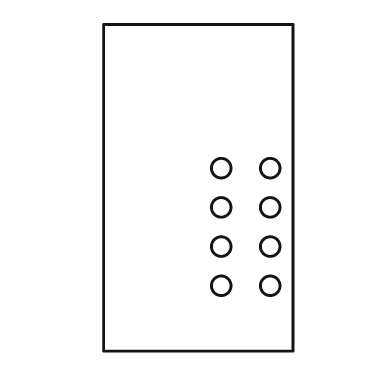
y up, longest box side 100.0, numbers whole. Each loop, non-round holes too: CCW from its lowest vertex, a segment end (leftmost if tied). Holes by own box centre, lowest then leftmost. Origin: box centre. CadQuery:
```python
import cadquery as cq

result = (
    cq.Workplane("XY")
    .moveTo(-29.0, -50.0)
    .lineTo(29.0, -50.0)
    .lineTo(29.0, 50.0)
    .lineTo(-29.0, 50.0)
    .close()
    .moveTo(7.0, -30.0)
    .circle(3.0)
    .moveTo(22.0, -30.0)
    .circle(3.0)
    .moveTo(7.0, -18.0)
    .circle(3.0)
    .moveTo(22.0, -18.0)
    .circle(3.0)
    .moveTo(7.0, -6.0)
    .circle(3.0)
    .moveTo(22.0, -6.0)
    .circle(3.0)
    .moveTo(7.0, 6.0)
    .circle(3.0)
    .moveTo(22.0, 6.0)
    .circle(3.0)
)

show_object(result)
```